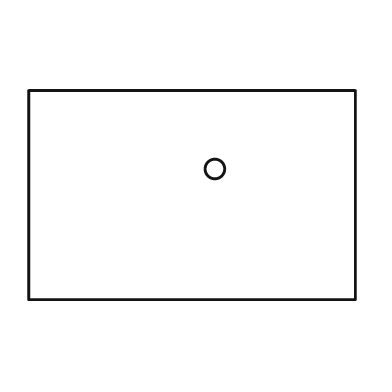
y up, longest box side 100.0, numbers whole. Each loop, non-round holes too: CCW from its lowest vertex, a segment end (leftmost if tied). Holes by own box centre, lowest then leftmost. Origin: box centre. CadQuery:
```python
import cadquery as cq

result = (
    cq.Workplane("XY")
    .moveTo(-50.0, -32.0)
    .lineTo(50.0, -32.0)
    .lineTo(50.0, 32.0)
    .lineTo(-50.0, 32.0)
    .close()
    .moveTo(7.0, 8.0)
    .circle(3.0)
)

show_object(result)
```